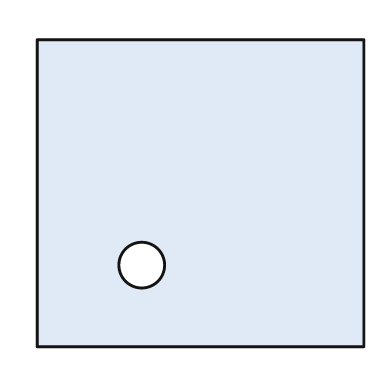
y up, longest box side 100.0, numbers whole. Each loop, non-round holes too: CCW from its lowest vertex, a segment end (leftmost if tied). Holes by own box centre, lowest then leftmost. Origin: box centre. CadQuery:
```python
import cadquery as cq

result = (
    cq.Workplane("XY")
    .moveTo(-50.0, -47.0)
    .lineTo(50.0, -47.0)
    .lineTo(50.0, 47.0)
    .lineTo(-50.0, 47.0)
    .close()
    .moveTo(-18.0, -22.0)
    .circle(7.0)
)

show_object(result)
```